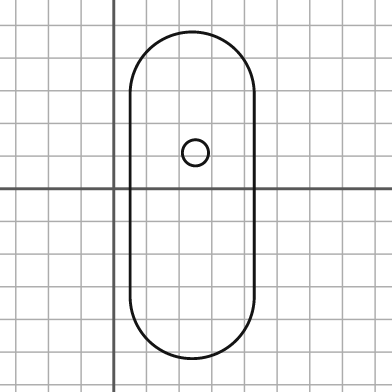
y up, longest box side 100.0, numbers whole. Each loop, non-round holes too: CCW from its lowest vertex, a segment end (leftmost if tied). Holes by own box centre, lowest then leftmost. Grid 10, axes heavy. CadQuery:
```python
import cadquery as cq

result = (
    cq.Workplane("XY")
    .moveTo(5.0, -33.0)
    .threePointArc((24.0, -52.0), (43.0, -33.0))
    .lineTo(43.0, 29.0)
    .threePointArc((24.0, 48.0), (5.0, 29.0))
    .close()
    .moveTo(25.0, 11.0)
    .circle(4.0)
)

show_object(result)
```